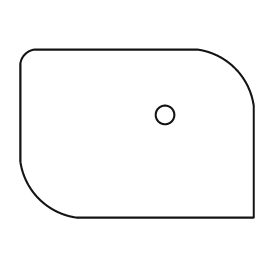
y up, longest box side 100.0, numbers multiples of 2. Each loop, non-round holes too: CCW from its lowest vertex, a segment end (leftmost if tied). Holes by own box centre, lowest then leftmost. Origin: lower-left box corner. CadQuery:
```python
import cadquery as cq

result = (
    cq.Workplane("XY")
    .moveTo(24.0, 0.0)
    .lineTo(100.0, 0.0)
    .lineTo(100.0, 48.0)
    .threePointArc((92.0, 64.0), (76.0, 72.0))
    .lineTo(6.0, 72.0)
    .threePointArc((2.0, 70.0), (0.0, 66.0))
    .lineTo(0.0, 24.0)
    .threePointArc((8.0, 8.0), (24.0, 0.0))
    .close()
    .moveTo(62.0, 44.0)
    .circle(4.0)
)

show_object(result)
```